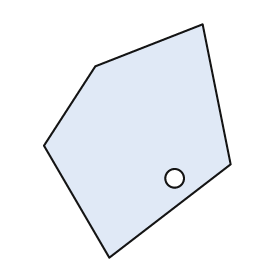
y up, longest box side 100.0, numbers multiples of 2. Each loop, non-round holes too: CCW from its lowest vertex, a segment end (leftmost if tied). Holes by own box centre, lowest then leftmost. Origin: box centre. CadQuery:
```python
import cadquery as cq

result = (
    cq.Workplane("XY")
    .moveTo(-12.0, -50.0)
    .lineTo(40.0, -10.0)
    .lineTo(28.0, 50.0)
    .lineTo(-18.0, 32.0)
    .lineTo(-40.0, -2.0)
    .close()
    .moveTo(16.0, -16.0)
    .circle(4.0)
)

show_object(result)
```